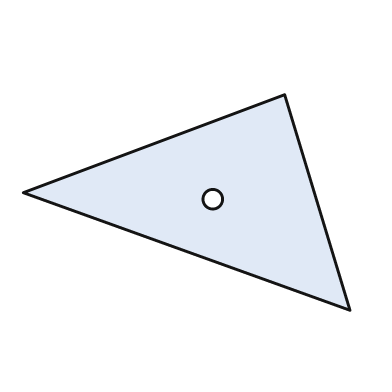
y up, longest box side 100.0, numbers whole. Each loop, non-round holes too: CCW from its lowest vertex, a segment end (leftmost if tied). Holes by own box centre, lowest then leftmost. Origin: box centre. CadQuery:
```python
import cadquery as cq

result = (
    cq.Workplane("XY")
    .moveTo(50.0, -33.0)
    .lineTo(30.0, 33.0)
    .lineTo(-50.0, 3.0)
    .close()
    .moveTo(8.0, 1.0)
    .circle(3.0)
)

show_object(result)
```